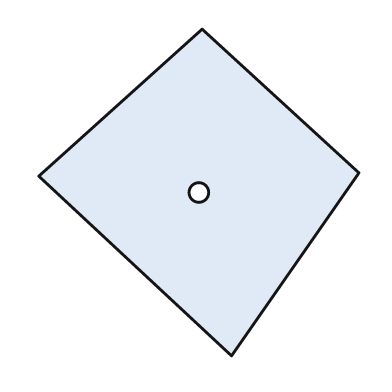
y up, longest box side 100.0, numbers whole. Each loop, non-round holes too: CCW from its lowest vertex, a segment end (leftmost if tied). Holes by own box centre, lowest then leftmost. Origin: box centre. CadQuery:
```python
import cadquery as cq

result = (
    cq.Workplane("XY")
    .moveTo(10.0, -50.0)
    .lineTo(49.0, 6.0)
    .lineTo(1.0, 50.0)
    .lineTo(-49.0, 5.0)
    .close()
    .moveTo(0.0, 0.0)
    .circle(3.0)
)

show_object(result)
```